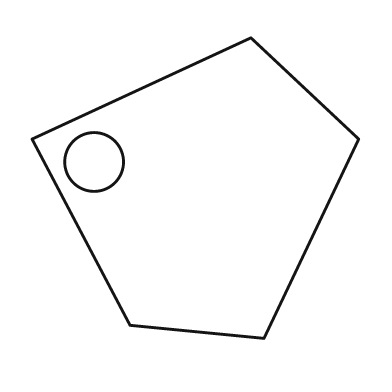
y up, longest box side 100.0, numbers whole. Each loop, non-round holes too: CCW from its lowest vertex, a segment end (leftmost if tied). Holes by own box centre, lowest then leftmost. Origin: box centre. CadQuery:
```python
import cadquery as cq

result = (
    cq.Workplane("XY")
    .moveTo(21.0, -46.0)
    .lineTo(50.0, 15.0)
    .lineTo(17.0, 46.0)
    .lineTo(-50.0, 15.0)
    .lineTo(-20.0, -42.0)
    .close()
    .moveTo(-31.0, 8.0)
    .circle(9.0)
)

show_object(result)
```